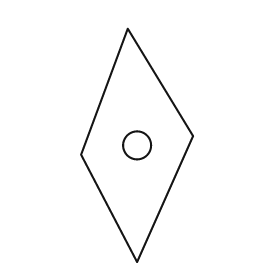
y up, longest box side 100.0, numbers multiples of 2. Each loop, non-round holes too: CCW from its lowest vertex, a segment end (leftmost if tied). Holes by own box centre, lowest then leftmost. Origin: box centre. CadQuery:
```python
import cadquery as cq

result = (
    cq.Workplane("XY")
    .moveTo(0.0, -50.0)
    .lineTo(24.0, 4.0)
    .lineTo(-4.0, 50.0)
    .lineTo(-24.0, -4.0)
    .close()
    .moveTo(0.0, 0.0)
    .circle(6.0)
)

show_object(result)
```